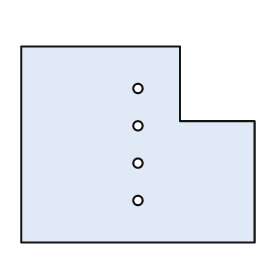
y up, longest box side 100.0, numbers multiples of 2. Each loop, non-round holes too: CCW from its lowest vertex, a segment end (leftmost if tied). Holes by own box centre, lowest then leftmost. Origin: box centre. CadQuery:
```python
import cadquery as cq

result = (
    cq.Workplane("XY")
    .moveTo(-50.0, -42.0)
    .lineTo(50.0, -42.0)
    .lineTo(50.0, 10.0)
    .lineTo(18.0, 10.0)
    .lineTo(18.0, 42.0)
    .lineTo(-50.0, 42.0)
    .close()
    .moveTo(0.0, -24.0)
    .circle(2.0)
    .moveTo(0.0, -8.0)
    .circle(2.0)
    .moveTo(0.0, 8.0)
    .circle(2.0)
    .moveTo(0.0, 24.0)
    .circle(2.0)
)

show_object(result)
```